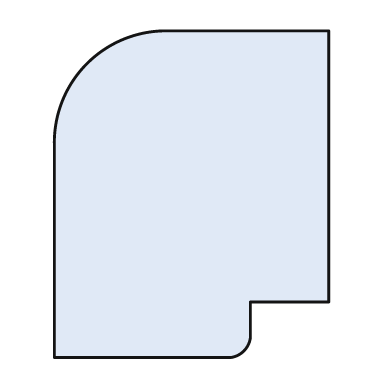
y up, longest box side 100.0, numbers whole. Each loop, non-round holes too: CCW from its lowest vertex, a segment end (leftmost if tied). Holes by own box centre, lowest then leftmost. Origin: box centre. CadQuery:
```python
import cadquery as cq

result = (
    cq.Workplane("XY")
    .moveTo(-42.0, -50.0)
    .lineTo(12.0, -50.0)
    .threePointArc((16.0, -48.0), (18.0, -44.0))
    .lineTo(18.0, -33.0)
    .lineTo(42.0, -33.0)
    .lineTo(42.0, 50.0)
    .lineTo(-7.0, 50.0)
    .threePointArc((-32.0, 40.0), (-42.0, 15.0))
    .close()
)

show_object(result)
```